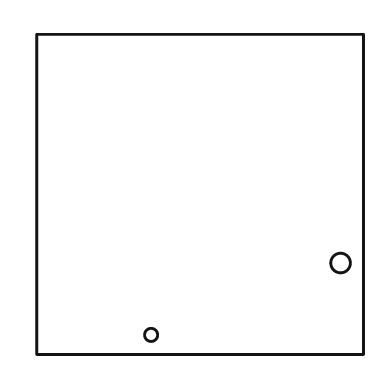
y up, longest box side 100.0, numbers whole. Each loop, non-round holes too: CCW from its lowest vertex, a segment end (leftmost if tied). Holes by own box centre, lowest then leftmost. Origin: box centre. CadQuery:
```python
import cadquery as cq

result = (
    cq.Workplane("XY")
    .moveTo(-50.0, -49.0)
    .lineTo(50.0, -49.0)
    .lineTo(50.0, 49.0)
    .lineTo(-50.0, 49.0)
    .close()
    .moveTo(-15.0, -43.0)
    .circle(2.0)
    .moveTo(43.0, -21.0)
    .circle(3.0)
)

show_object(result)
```